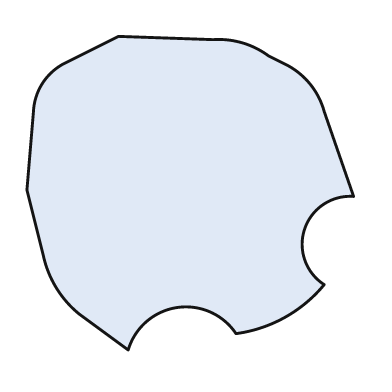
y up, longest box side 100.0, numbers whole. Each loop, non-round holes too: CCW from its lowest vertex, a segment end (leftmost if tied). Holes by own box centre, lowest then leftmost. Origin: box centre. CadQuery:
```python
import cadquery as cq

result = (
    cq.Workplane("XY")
    .moveTo(-19.0, -48.0)
    .threePointArc((-4.0, -35.0), (14.0, -43.0))
    .threePointArc((29.0, -38.0), (41.0, -28.0))
    .threePointArc((35.0, -11.0), (50.0, -1.0))
    .lineTo(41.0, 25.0)
    .threePointArc((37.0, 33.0), (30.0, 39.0))
    .lineTo(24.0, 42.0)
    .threePointArc((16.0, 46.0), (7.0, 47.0))
    .lineTo(-22.0, 48.0)
    .lineTo(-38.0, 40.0)
    .threePointArc((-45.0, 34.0), (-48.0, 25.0))
    .lineTo(-50.0, 1.0)
    .lineTo(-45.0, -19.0)
    .threePointArc((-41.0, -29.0), (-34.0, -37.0))
    .close()
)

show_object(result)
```